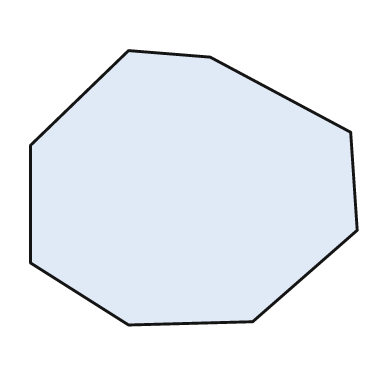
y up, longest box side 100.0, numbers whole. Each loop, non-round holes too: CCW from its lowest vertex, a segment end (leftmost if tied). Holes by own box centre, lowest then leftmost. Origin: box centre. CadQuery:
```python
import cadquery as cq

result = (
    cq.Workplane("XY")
    .moveTo(-20.0, -42.0)
    .lineTo(18.0, -41.0)
    .lineTo(50.0, -13.0)
    .lineTo(48.0, 17.0)
    .lineTo(5.0, 40.0)
    .lineTo(-20.0, 42.0)
    .lineTo(-50.0, 13.0)
    .lineTo(-50.0, -23.0)
    .close()
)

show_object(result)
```